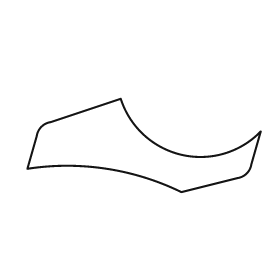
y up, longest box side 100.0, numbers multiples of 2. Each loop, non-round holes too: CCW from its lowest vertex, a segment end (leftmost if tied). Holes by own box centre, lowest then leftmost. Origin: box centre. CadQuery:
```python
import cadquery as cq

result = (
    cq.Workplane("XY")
    .moveTo(16.0, -20.0)
    .lineTo(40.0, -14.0)
    .threePointArc((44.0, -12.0), (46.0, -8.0))
    .lineTo(50.0, 6.0)
    .threePointArc((16.0, -4.0), (-10.0, 20.0))
    .lineTo(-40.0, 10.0)
    .threePointArc((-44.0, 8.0), (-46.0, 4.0))
    .lineTo(-50.0, -10.0)
    .threePointArc((-16.0, -10.0), (16.0, -20.0))
    .close()
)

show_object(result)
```